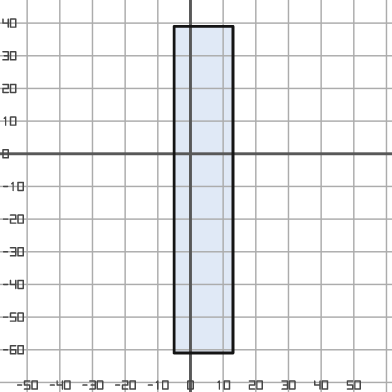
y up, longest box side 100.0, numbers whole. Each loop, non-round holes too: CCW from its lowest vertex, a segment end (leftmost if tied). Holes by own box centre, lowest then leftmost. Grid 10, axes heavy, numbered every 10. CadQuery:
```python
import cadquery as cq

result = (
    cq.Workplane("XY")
    .moveTo(-5.0, -61.0)
    .lineTo(13.0, -61.0)
    .lineTo(13.0, 39.0)
    .lineTo(-5.0, 39.0)
    .close()
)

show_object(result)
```